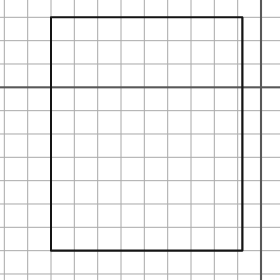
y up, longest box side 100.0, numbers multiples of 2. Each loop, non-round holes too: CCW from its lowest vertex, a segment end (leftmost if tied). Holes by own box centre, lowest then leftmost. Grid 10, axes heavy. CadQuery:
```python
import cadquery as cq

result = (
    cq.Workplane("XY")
    .moveTo(-90.0, -70.0)
    .lineTo(-8.0, -70.0)
    .lineTo(-8.0, 30.0)
    .lineTo(-90.0, 30.0)
    .close()
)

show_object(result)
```